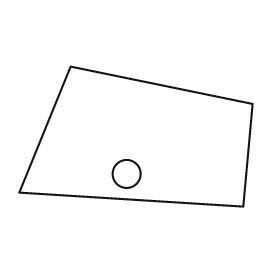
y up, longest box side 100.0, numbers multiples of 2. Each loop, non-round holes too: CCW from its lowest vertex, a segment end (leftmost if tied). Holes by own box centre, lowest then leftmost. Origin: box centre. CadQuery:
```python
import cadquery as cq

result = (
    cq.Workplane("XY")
    .moveTo(46.0, -30.0)
    .lineTo(50.0, 14.0)
    .lineTo(-28.0, 30.0)
    .lineTo(-50.0, -24.0)
    .close()
    .moveTo(-4.0, -16.0)
    .circle(6.0)
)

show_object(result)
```